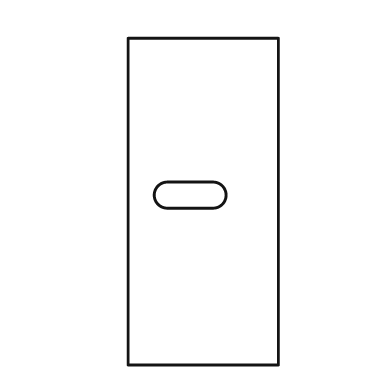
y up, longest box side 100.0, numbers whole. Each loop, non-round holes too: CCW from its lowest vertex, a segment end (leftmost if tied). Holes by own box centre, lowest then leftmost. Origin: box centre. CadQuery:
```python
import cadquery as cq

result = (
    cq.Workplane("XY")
    .moveTo(-23.0, -50.0)
    .lineTo(23.0, -50.0)
    .lineTo(23.0, 50.0)
    .lineTo(-23.0, 50.0)
    .close()
    .moveTo(-11.0, -2.0)
    .lineTo(3.0, -2.0)
    .threePointArc((7.0, 2.0), (3.0, 6.0))
    .lineTo(-11.0, 6.0)
    .threePointArc((-15.0, 2.0), (-11.0, -2.0))
    .close()
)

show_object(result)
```